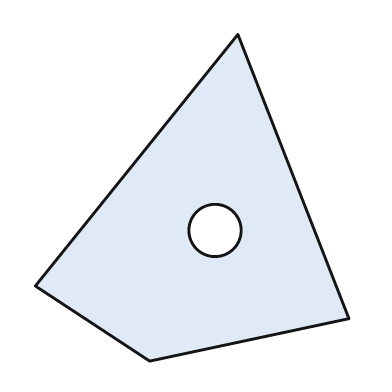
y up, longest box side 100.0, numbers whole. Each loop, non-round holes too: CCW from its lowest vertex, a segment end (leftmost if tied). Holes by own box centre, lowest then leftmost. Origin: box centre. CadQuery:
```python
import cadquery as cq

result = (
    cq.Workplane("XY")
    .moveTo(-13.0, -50.0)
    .lineTo(48.0, -37.0)
    .lineTo(14.0, 50.0)
    .lineTo(-48.0, -27.0)
    .close()
    .moveTo(7.0, -10.0)
    .circle(8.0)
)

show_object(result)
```